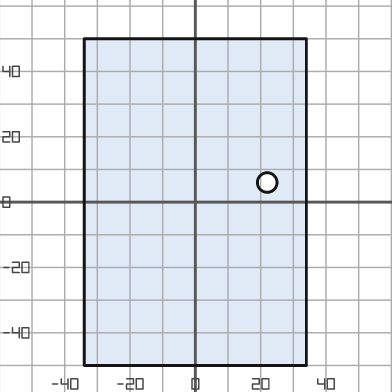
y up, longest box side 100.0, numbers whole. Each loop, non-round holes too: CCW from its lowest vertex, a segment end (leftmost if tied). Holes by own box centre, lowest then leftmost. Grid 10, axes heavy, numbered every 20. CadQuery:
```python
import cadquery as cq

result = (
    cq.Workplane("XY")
    .moveTo(-34.0, -50.0)
    .lineTo(34.0, -50.0)
    .lineTo(34.0, 50.0)
    .lineTo(-34.0, 50.0)
    .close()
    .moveTo(22.0, 6.0)
    .circle(3.0)
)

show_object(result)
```